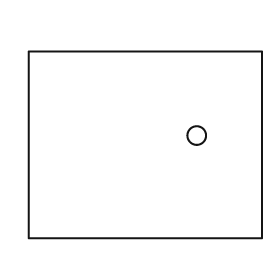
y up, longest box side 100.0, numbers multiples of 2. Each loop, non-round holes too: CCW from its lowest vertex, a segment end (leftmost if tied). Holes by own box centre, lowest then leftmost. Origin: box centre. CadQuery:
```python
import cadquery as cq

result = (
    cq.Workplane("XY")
    .moveTo(-50.0, -40.0)
    .lineTo(50.0, -40.0)
    .lineTo(50.0, 40.0)
    .lineTo(-50.0, 40.0)
    .close()
    .moveTo(22.0, 4.0)
    .circle(4.0)
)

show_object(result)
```